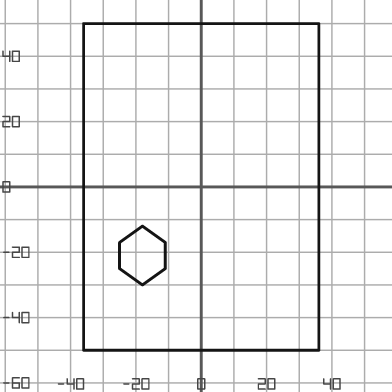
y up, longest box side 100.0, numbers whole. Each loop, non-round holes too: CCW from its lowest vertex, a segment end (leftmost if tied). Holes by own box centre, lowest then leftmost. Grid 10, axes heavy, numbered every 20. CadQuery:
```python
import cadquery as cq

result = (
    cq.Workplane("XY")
    .moveTo(-36.0, -50.0)
    .lineTo(36.0, -50.0)
    .lineTo(36.0, 50.0)
    .lineTo(-36.0, 50.0)
    .close()
    .moveTo(-18.0, -30.0)
    .lineTo(-11.0, -25.0)
    .lineTo(-11.0, -17.0)
    .lineTo(-18.0, -12.0)
    .lineTo(-25.0, -17.0)
    .lineTo(-25.0, -25.0)
    .close()
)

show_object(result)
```